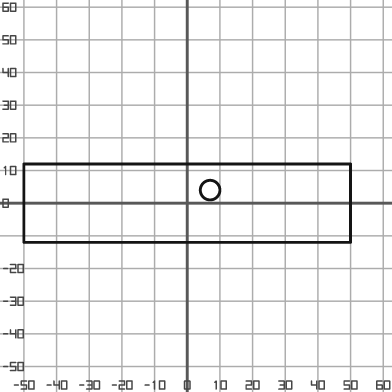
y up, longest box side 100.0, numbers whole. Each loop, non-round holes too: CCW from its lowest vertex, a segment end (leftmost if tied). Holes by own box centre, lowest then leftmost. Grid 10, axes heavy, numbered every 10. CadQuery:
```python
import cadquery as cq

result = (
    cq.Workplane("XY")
    .moveTo(-50.0, -12.0)
    .lineTo(50.0, -12.0)
    .lineTo(50.0, 12.0)
    .lineTo(-50.0, 12.0)
    .close()
    .moveTo(7.0, 4.0)
    .circle(3.0)
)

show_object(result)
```